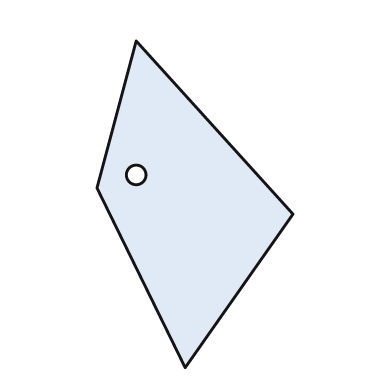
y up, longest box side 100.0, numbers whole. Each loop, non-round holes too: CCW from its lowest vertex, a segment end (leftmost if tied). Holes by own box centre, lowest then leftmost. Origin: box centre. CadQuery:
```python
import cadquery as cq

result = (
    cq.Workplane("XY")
    .moveTo(-3.0, -50.0)
    .lineTo(30.0, -3.0)
    .lineTo(-18.0, 50.0)
    .lineTo(-30.0, 5.0)
    .close()
    .moveTo(-18.0, 9.0)
    .circle(3.0)
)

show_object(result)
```